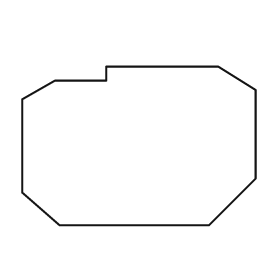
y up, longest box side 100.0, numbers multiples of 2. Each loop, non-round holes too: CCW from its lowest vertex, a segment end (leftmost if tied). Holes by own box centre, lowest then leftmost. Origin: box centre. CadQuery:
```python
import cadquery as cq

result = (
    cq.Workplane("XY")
    .moveTo(-34.0, -34.0)
    .lineTo(30.0, -34.0)
    .lineTo(50.0, -14.0)
    .lineTo(50.0, 24.0)
    .lineTo(34.0, 34.0)
    .lineTo(-14.0, 34.0)
    .lineTo(-14.0, 28.0)
    .lineTo(-36.0, 28.0)
    .lineTo(-50.0, 20.0)
    .lineTo(-50.0, -20.0)
    .close()
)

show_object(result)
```